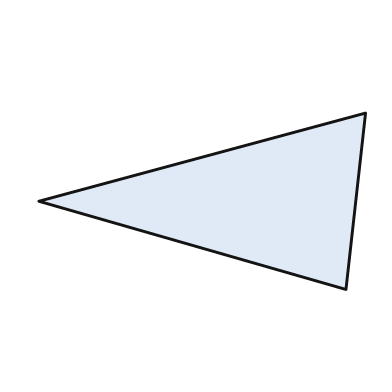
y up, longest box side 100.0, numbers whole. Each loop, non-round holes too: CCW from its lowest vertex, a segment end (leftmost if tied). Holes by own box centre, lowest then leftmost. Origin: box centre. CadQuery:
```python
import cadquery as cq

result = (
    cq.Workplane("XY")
    .moveTo(44.0, -27.0)
    .lineTo(50.0, 27.0)
    .lineTo(-50.0, 0.0)
    .close()
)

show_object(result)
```